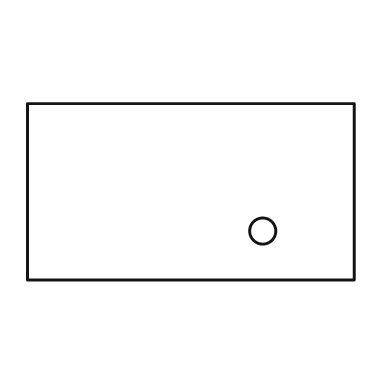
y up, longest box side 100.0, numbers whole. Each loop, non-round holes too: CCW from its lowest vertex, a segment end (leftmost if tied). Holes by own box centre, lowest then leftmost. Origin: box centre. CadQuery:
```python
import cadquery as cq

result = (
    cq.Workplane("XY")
    .moveTo(-50.0, -27.0)
    .lineTo(50.0, -27.0)
    .lineTo(50.0, 27.0)
    .lineTo(-50.0, 27.0)
    .close()
    .moveTo(22.0, -12.0)
    .circle(4.0)
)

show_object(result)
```